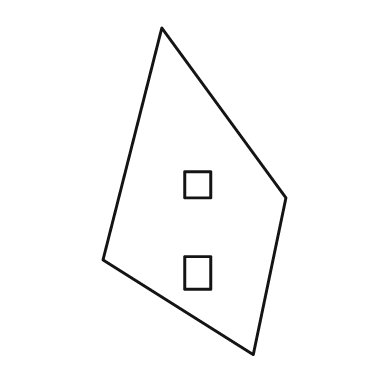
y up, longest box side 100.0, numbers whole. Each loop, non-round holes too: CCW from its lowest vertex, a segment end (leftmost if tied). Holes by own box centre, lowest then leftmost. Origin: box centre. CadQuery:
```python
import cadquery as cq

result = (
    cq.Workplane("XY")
    .moveTo(18.0, -50.0)
    .lineTo(28.0, -2.0)
    .lineTo(-10.0, 50.0)
    .lineTo(-28.0, -21.0)
    .close()
    .moveTo(-3.0, -30.0)
    .lineTo(5.0, -30.0)
    .lineTo(5.0, -20.0)
    .lineTo(-3.0, -20.0)
    .close()
    .moveTo(-3.0, -2.0)
    .lineTo(5.0, -2.0)
    .lineTo(5.0, 6.0)
    .lineTo(-3.0, 6.0)
    .close()
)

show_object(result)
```